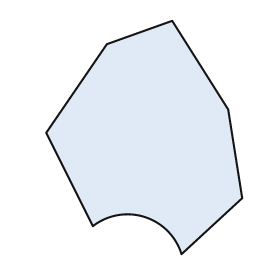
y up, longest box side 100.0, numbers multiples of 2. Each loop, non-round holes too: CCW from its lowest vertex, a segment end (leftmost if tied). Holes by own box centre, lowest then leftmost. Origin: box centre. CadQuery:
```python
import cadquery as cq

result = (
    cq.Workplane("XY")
    .moveTo(16.0, -50.0)
    .lineTo(42.0, -26.0)
    .lineTo(36.0, 12.0)
    .lineTo(12.0, 50.0)
    .lineTo(-16.0, 40.0)
    .lineTo(-42.0, 2.0)
    .lineTo(-22.0, -38.0)
    .threePointArc((0.0, -34.0), (16.0, -50.0))
    .close()
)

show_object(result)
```